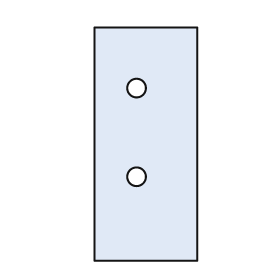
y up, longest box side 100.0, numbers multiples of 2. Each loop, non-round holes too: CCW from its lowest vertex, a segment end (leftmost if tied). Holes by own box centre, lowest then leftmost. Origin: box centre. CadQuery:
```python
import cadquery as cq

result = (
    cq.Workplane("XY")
    .moveTo(-22.0, -50.0)
    .lineTo(22.0, -50.0)
    .lineTo(22.0, 50.0)
    .lineTo(-22.0, 50.0)
    .close()
    .moveTo(-4.0, -14.0)
    .circle(4.0)
    .moveTo(-4.0, 24.0)
    .circle(4.0)
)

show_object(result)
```